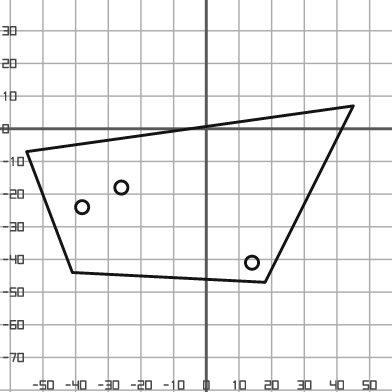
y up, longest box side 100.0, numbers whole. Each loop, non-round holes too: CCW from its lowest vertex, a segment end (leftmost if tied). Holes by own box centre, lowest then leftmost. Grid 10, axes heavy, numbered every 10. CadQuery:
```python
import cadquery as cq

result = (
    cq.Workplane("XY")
    .moveTo(18.0, -47.0)
    .lineTo(45.0, 7.0)
    .lineTo(-55.0, -7.0)
    .lineTo(-41.0, -44.0)
    .close()
    .moveTo(14.0, -41.0)
    .circle(2.0)
    .moveTo(-38.0, -24.0)
    .circle(2.0)
    .moveTo(-26.0, -18.0)
    .circle(2.0)
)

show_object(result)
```